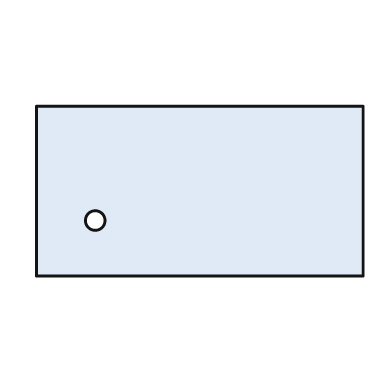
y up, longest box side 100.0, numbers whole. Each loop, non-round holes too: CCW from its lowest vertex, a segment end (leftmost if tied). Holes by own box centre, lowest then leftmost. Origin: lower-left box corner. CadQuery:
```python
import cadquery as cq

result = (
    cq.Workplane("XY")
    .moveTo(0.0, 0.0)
    .lineTo(100.0, 0.0)
    .lineTo(100.0, 52.0)
    .lineTo(0.0, 52.0)
    .close()
    .moveTo(18.0, 17.0)
    .circle(3.0)
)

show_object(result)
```